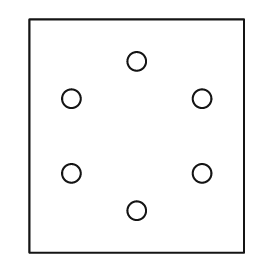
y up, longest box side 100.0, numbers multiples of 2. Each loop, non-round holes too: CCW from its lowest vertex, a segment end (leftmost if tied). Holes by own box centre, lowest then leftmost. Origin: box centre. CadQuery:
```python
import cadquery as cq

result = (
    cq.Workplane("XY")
    .moveTo(-46.0, -50.0)
    .lineTo(46.0, -50.0)
    .lineTo(46.0, 50.0)
    .lineTo(-46.0, 50.0)
    .close()
    .moveTo(0.0, -32.0)
    .circle(4.0)
    .moveTo(-28.0, -16.0)
    .circle(4.0)
    .moveTo(28.0, -16.0)
    .circle(4.0)
    .moveTo(-28.0, 16.0)
    .circle(4.0)
    .moveTo(28.0, 16.0)
    .circle(4.0)
    .moveTo(0.0, 32.0)
    .circle(4.0)
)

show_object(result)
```